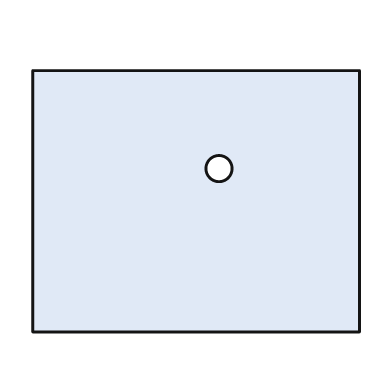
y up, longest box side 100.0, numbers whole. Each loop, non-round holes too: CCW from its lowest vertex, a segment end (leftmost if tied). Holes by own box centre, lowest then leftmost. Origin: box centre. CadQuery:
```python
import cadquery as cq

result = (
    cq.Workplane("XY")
    .moveTo(-50.0, -40.0)
    .lineTo(50.0, -40.0)
    .lineTo(50.0, 40.0)
    .lineTo(-50.0, 40.0)
    .close()
    .moveTo(7.0, 10.0)
    .circle(4.0)
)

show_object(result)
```